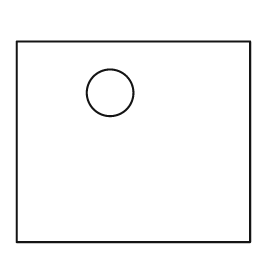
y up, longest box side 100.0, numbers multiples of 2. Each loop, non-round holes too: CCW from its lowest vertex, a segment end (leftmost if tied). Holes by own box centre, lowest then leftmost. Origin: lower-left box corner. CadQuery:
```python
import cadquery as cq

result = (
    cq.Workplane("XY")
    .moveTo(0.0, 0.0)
    .lineTo(100.0, 0.0)
    .lineTo(100.0, 86.0)
    .lineTo(0.0, 86.0)
    .close()
    .moveTo(40.0, 64.0)
    .circle(10.0)
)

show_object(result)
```